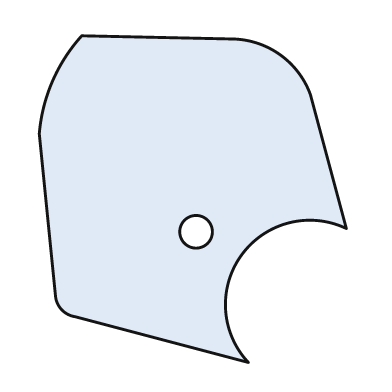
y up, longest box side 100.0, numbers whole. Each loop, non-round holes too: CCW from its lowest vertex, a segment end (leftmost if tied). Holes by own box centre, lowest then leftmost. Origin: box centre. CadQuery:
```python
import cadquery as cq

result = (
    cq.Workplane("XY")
    .moveTo(17.0, -50.0)
    .threePointArc((15.0, -17.0), (47.0, -9.0))
    .lineTo(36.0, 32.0)
    .threePointArc((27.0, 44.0), (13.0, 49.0))
    .lineTo(-34.0, 50.0)
    .threePointArc((-43.0, 36.0), (-47.0, 20.0))
    .lineTo(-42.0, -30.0)
    .threePointArc((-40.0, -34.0), (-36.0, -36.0))
    .close()
    .moveTo(1.0, -10.0)
    .circle(5.0)
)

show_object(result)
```